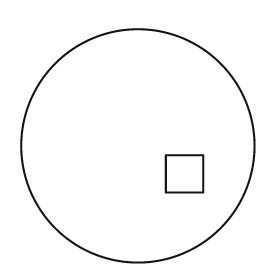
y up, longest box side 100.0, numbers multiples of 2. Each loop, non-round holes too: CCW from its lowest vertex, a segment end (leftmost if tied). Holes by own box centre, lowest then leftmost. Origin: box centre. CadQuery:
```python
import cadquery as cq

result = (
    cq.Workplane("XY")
    .moveTo(0.0, 0.0)
    .circle(50.0)
    .moveTo(12.0, -20.0)
    .lineTo(28.0, -20.0)
    .lineTo(28.0, -4.0)
    .lineTo(12.0, -4.0)
    .close()
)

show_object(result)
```